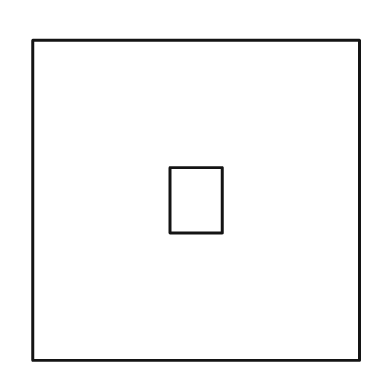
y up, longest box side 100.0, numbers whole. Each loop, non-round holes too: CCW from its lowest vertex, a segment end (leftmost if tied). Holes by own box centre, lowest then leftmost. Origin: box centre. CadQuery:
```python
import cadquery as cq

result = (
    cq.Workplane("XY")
    .moveTo(-50.0, -49.0)
    .lineTo(50.0, -49.0)
    .lineTo(50.0, 49.0)
    .lineTo(-50.0, 49.0)
    .close()
    .moveTo(-8.0, -10.0)
    .lineTo(8.0, -10.0)
    .lineTo(8.0, 10.0)
    .lineTo(-8.0, 10.0)
    .close()
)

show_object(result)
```